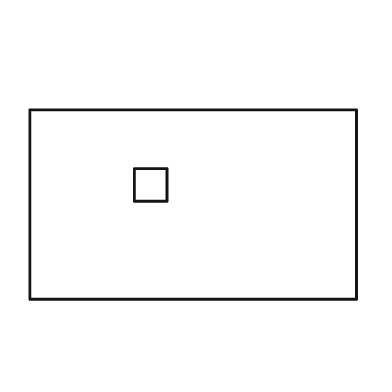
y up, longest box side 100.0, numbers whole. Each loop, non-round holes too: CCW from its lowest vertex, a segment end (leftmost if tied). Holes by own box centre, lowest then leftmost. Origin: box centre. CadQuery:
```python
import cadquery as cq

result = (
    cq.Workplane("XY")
    .moveTo(-50.0, -29.0)
    .lineTo(50.0, -29.0)
    .lineTo(50.0, 29.0)
    .lineTo(-50.0, 29.0)
    .close()
    .moveTo(-18.0, 1.0)
    .lineTo(-8.0, 1.0)
    .lineTo(-8.0, 11.0)
    .lineTo(-18.0, 11.0)
    .close()
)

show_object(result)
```